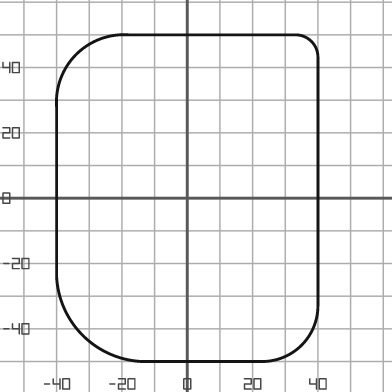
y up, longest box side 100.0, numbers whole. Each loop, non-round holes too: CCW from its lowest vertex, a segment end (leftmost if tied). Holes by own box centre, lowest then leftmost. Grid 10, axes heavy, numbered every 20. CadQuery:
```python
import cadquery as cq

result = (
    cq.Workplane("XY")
    .moveTo(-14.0, -50.0)
    .lineTo(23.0, -50.0)
    .threePointArc((35.0, -45.0), (40.0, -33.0))
    .lineTo(40.0, 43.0)
    .threePointArc((38.0, 48.0), (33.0, 50.0))
    .lineTo(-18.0, 50.0)
    .threePointArc((-34.0, 44.0), (-40.0, 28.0))
    .lineTo(-40.0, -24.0)
    .threePointArc((-32.0, -42.0), (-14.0, -50.0))
    .close()
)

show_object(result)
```